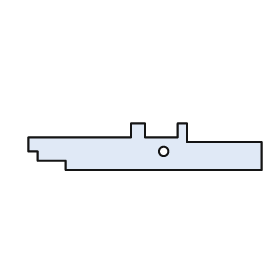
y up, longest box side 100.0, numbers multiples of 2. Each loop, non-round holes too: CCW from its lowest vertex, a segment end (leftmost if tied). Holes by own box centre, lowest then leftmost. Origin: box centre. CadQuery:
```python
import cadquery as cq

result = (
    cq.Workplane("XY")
    .moveTo(-34.0, -10.0)
    .lineTo(50.0, -10.0)
    .lineTo(50.0, 2.0)
    .lineTo(18.0, 2.0)
    .lineTo(18.0, 10.0)
    .lineTo(14.0, 10.0)
    .lineTo(14.0, 4.0)
    .lineTo(0.0, 4.0)
    .lineTo(0.0, 10.0)
    .lineTo(-6.0, 10.0)
    .lineTo(-6.0, 4.0)
    .lineTo(-50.0, 4.0)
    .lineTo(-50.0, -2.0)
    .lineTo(-46.0, -2.0)
    .lineTo(-46.0, -6.0)
    .lineTo(-34.0, -6.0)
    .close()
    .moveTo(8.0, -2.0)
    .circle(2.0)
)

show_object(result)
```